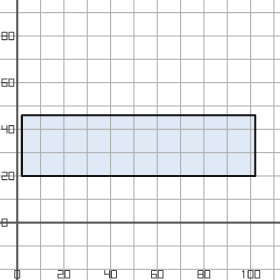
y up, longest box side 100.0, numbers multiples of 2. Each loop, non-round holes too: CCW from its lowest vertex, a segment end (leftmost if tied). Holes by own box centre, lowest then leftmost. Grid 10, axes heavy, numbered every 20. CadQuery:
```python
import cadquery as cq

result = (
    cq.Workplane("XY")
    .moveTo(2.0, 20.0)
    .lineTo(102.0, 20.0)
    .lineTo(102.0, 46.0)
    .lineTo(2.0, 46.0)
    .close()
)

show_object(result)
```